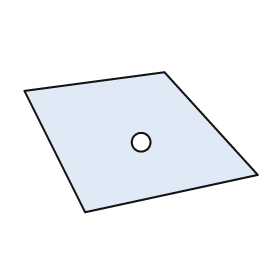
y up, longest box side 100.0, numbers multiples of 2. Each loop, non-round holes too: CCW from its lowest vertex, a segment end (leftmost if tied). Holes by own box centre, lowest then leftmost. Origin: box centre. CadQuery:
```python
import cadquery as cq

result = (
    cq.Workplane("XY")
    .moveTo(-24.0, -30.0)
    .lineTo(50.0, -14.0)
    .lineTo(10.0, 30.0)
    .lineTo(-50.0, 22.0)
    .close()
    .moveTo(0.0, 0.0)
    .circle(4.0)
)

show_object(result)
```